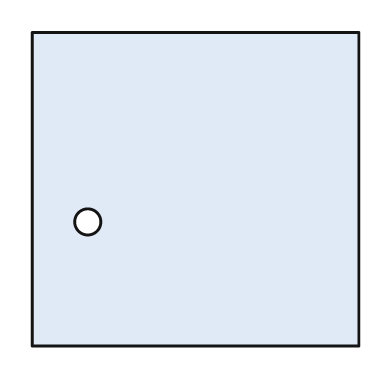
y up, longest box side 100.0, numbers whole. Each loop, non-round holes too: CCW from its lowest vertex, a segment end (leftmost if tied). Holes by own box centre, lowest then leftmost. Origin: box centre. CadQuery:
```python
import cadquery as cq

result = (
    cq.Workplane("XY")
    .moveTo(-50.0, -48.0)
    .lineTo(50.0, -48.0)
    .lineTo(50.0, 48.0)
    .lineTo(-50.0, 48.0)
    .close()
    .moveTo(-33.0, -10.0)
    .circle(4.0)
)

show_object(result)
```